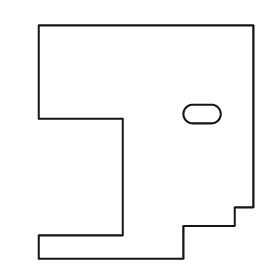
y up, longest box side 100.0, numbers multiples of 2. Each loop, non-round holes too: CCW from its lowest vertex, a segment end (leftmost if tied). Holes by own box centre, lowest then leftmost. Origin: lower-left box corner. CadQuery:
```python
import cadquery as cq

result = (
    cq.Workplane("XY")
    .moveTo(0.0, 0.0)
    .lineTo(62.0, 0.0)
    .lineTo(62.0, 14.0)
    .lineTo(84.0, 14.0)
    .lineTo(84.0, 22.0)
    .lineTo(92.0, 22.0)
    .lineTo(92.0, 100.0)
    .lineTo(0.0, 100.0)
    .lineTo(0.0, 60.0)
    .lineTo(36.0, 60.0)
    .lineTo(36.0, 10.0)
    .lineTo(0.0, 10.0)
    .close()
    .moveTo(66.0, 58.0)
    .lineTo(74.0, 58.0)
    .threePointArc((78.0, 62.0), (74.0, 66.0))
    .lineTo(66.0, 66.0)
    .threePointArc((62.0, 62.0), (66.0, 58.0))
    .close()
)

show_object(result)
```